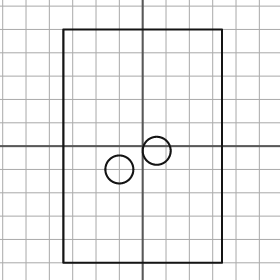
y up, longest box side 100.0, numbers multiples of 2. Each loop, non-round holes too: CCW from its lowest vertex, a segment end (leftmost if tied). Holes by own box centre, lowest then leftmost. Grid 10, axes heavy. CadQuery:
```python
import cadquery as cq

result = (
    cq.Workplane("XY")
    .moveTo(-34.0, -50.0)
    .lineTo(34.0, -50.0)
    .lineTo(34.0, 50.0)
    .lineTo(-34.0, 50.0)
    .close()
    .moveTo(-10.0, -10.0)
    .circle(6.0)
    .moveTo(6.0, -2.0)
    .circle(6.0)
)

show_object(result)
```